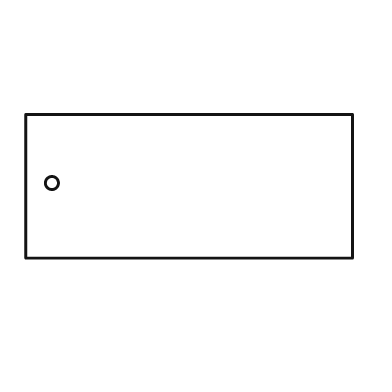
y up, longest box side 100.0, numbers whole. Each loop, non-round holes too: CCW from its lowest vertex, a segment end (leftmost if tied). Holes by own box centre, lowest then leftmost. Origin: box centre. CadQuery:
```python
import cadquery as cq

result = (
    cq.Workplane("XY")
    .moveTo(-50.0, -22.0)
    .lineTo(50.0, -22.0)
    .lineTo(50.0, 22.0)
    .lineTo(-50.0, 22.0)
    .close()
    .moveTo(-42.0, 1.0)
    .circle(2.0)
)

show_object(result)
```